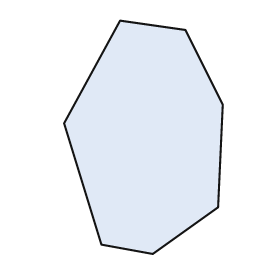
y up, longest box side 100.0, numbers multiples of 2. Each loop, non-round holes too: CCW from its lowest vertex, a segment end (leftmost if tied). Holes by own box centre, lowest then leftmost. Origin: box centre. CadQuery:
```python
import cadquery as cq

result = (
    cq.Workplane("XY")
    .moveTo(4.0, -50.0)
    .lineTo(32.0, -30.0)
    .lineTo(34.0, 14.0)
    .lineTo(18.0, 46.0)
    .lineTo(-10.0, 50.0)
    .lineTo(-34.0, 6.0)
    .lineTo(-18.0, -46.0)
    .close()
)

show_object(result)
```